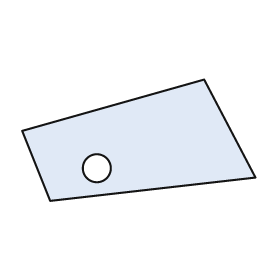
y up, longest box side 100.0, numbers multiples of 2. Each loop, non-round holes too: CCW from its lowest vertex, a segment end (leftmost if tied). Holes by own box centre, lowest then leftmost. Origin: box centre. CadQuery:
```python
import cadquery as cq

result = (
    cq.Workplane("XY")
    .moveTo(-38.0, -26.0)
    .lineTo(50.0, -16.0)
    .lineTo(28.0, 26.0)
    .lineTo(-50.0, 4.0)
    .close()
    .moveTo(-18.0, -12.0)
    .circle(6.0)
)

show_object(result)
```